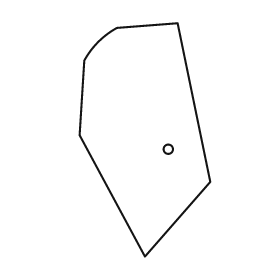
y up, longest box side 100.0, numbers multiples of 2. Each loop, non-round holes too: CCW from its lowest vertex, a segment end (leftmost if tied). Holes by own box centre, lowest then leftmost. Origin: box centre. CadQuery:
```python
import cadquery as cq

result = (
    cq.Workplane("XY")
    .moveTo(0.0, -50.0)
    .lineTo(28.0, -18.0)
    .lineTo(14.0, 50.0)
    .lineTo(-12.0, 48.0)
    .threePointArc((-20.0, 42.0), (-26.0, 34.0))
    .lineTo(-28.0, 2.0)
    .close()
    .moveTo(10.0, -4.0)
    .circle(2.0)
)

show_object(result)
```